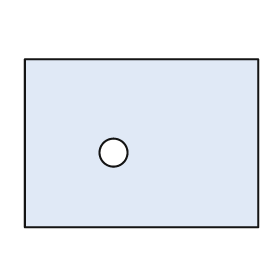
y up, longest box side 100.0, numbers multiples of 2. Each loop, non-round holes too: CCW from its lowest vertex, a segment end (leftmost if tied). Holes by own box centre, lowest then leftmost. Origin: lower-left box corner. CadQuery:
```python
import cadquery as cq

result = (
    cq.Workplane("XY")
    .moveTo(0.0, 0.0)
    .lineTo(100.0, 0.0)
    .lineTo(100.0, 72.0)
    .lineTo(0.0, 72.0)
    .close()
    .moveTo(38.0, 32.0)
    .circle(6.0)
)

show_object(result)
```